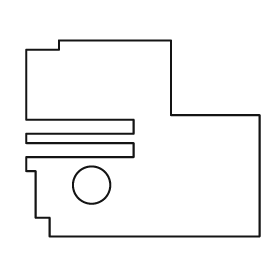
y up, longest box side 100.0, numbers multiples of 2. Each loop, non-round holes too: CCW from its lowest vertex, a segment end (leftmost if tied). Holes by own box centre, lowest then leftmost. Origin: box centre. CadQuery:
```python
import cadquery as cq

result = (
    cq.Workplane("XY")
    .moveTo(-40.0, -42.0)
    .lineTo(50.0, -42.0)
    .lineTo(50.0, 10.0)
    .lineTo(12.0, 10.0)
    .lineTo(12.0, 42.0)
    .lineTo(-36.0, 42.0)
    .lineTo(-36.0, 38.0)
    .lineTo(-50.0, 38.0)
    .lineTo(-50.0, 8.0)
    .lineTo(-4.0, 8.0)
    .lineTo(-4.0, 2.0)
    .lineTo(-50.0, 2.0)
    .lineTo(-50.0, -2.0)
    .lineTo(-4.0, -2.0)
    .lineTo(-4.0, -8.0)
    .lineTo(-50.0, -8.0)
    .lineTo(-50.0, -14.0)
    .lineTo(-46.0, -14.0)
    .lineTo(-46.0, -34.0)
    .lineTo(-40.0, -34.0)
    .close()
    .moveTo(-22.0, -20.0)
    .circle(8.0)
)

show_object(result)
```